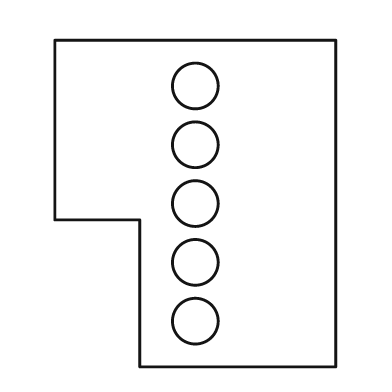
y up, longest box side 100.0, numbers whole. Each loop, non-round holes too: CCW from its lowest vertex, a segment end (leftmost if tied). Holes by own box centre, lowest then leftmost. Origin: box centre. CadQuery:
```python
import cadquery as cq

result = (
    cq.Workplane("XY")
    .moveTo(-17.0, -50.0)
    .lineTo(43.0, -50.0)
    .lineTo(43.0, 50.0)
    .lineTo(-43.0, 50.0)
    .lineTo(-43.0, -5.0)
    .lineTo(-17.0, -5.0)
    .close()
    .moveTo(0.0, -36.0)
    .circle(7.0)
    .moveTo(0.0, -18.0)
    .circle(7.0)
    .moveTo(0.0, 0.0)
    .circle(7.0)
    .moveTo(0.0, 18.0)
    .circle(7.0)
    .moveTo(0.0, 36.0)
    .circle(7.0)
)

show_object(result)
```